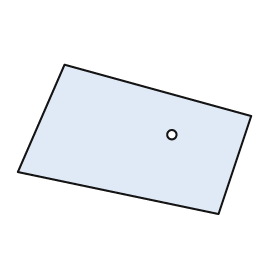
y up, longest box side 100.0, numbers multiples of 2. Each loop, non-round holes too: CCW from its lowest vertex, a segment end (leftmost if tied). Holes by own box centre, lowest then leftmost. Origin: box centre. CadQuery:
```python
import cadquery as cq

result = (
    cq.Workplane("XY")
    .moveTo(36.0, -32.0)
    .lineTo(50.0, 10.0)
    .lineTo(-30.0, 32.0)
    .lineTo(-50.0, -14.0)
    .close()
    .moveTo(16.0, 2.0)
    .circle(2.0)
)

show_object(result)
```